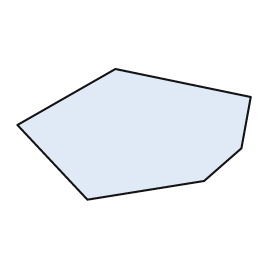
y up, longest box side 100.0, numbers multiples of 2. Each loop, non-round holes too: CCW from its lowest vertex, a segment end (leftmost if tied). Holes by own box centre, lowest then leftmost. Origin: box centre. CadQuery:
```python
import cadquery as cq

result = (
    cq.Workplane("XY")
    .moveTo(-20.0, -28.0)
    .lineTo(30.0, -20.0)
    .lineTo(46.0, -6.0)
    .lineTo(50.0, 16.0)
    .lineTo(-8.0, 28.0)
    .lineTo(-50.0, 4.0)
    .close()
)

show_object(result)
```